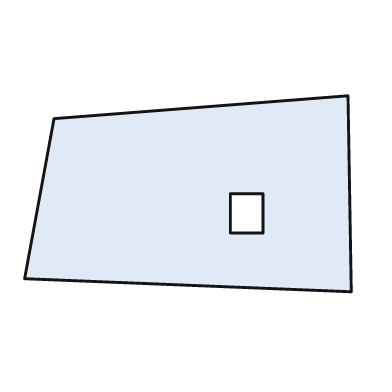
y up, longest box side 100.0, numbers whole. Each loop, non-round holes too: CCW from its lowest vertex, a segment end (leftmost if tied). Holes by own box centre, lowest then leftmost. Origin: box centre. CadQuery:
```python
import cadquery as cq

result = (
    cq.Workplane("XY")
    .moveTo(50.0, -30.0)
    .lineTo(49.0, 30.0)
    .lineTo(-41.0, 23.0)
    .lineTo(-50.0, -26.0)
    .close()
    .moveTo(13.0, -12.0)
    .lineTo(23.0, -12.0)
    .lineTo(23.0, 0.0)
    .lineTo(13.0, 0.0)
    .close()
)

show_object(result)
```